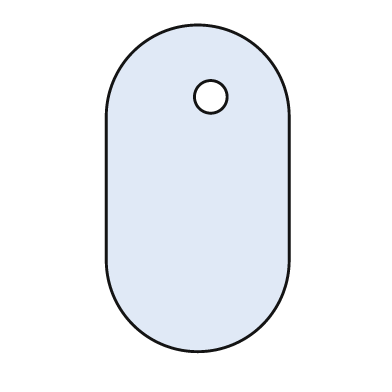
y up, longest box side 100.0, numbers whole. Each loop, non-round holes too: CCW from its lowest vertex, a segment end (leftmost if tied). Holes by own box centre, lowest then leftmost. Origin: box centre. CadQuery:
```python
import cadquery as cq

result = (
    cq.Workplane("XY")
    .moveTo(-28.0, -22.0)
    .threePointArc((0.0, -50.0), (28.0, -22.0))
    .lineTo(28.0, 22.0)
    .threePointArc((0.0, 50.0), (-28.0, 22.0))
    .close()
    .moveTo(4.0, 28.0)
    .circle(5.0)
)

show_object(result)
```